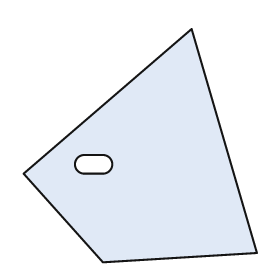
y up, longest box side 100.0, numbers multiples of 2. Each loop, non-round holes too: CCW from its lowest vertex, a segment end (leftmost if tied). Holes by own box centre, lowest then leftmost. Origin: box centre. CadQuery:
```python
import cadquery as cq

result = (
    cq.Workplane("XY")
    .moveTo(-16.0, -50.0)
    .lineTo(50.0, -46.0)
    .lineTo(22.0, 50.0)
    .lineTo(-50.0, -12.0)
    .close()
    .moveTo(-24.0, -12.0)
    .lineTo(-16.0, -12.0)
    .threePointArc((-12.0, -8.0), (-16.0, -4.0))
    .lineTo(-24.0, -4.0)
    .threePointArc((-28.0, -8.0), (-24.0, -12.0))
    .close()
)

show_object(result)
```